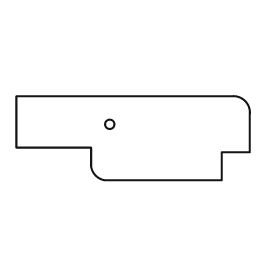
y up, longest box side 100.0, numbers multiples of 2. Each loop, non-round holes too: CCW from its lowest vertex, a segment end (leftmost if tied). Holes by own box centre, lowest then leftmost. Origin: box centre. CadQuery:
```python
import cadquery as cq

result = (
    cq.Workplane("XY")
    .moveTo(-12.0, -18.0)
    .lineTo(38.0, -18.0)
    .lineTo(38.0, -6.0)
    .lineTo(50.0, -6.0)
    .lineTo(50.0, 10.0)
    .threePointArc((48.0, 16.0), (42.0, 18.0))
    .lineTo(-50.0, 18.0)
    .lineTo(-50.0, -4.0)
    .lineTo(-18.0, -4.0)
    .lineTo(-18.0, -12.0)
    .threePointArc((-16.0, -16.0), (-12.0, -18.0))
    .close()
    .moveTo(-10.0, 6.0)
    .circle(2.0)
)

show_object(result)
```